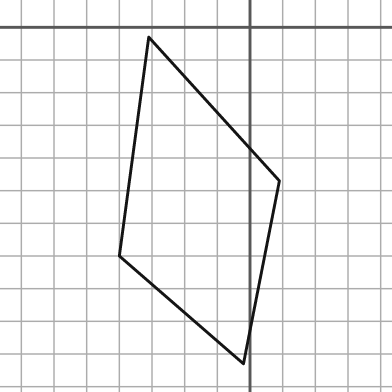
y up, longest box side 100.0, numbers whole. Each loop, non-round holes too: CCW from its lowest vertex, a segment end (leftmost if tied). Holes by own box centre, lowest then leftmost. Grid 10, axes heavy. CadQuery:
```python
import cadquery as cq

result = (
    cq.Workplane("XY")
    .moveTo(-2.0, -103.0)
    .lineTo(9.0, -47.0)
    .lineTo(-31.0, -3.0)
    .lineTo(-40.0, -70.0)
    .close()
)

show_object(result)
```